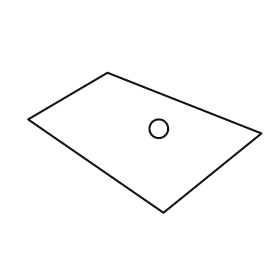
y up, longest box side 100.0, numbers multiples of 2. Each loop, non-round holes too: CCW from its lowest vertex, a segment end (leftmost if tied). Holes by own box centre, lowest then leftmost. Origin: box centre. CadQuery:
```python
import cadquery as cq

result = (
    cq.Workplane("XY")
    .moveTo(8.0, -30.0)
    .lineTo(50.0, 4.0)
    .lineTo(-16.0, 30.0)
    .lineTo(-50.0, 10.0)
    .close()
    .moveTo(6.0, 6.0)
    .circle(4.0)
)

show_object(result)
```